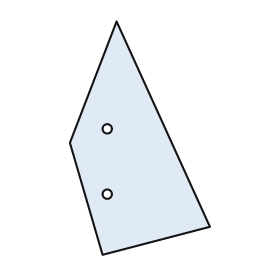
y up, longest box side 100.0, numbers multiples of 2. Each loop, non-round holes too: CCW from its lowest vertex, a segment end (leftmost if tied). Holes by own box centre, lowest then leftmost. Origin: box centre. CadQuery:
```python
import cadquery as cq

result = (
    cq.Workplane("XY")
    .moveTo(-16.0, -50.0)
    .lineTo(30.0, -38.0)
    .lineTo(-10.0, 50.0)
    .lineTo(-30.0, -2.0)
    .close()
    .moveTo(-14.0, -24.0)
    .circle(2.0)
    .moveTo(-14.0, 4.0)
    .circle(2.0)
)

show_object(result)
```